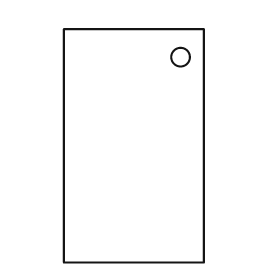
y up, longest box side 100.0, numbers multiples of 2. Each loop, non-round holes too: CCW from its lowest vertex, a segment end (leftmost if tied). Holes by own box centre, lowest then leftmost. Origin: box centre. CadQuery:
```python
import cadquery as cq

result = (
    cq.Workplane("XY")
    .moveTo(-30.0, -50.0)
    .lineTo(30.0, -50.0)
    .lineTo(30.0, 50.0)
    .lineTo(-30.0, 50.0)
    .close()
    .moveTo(20.0, 38.0)
    .circle(4.0)
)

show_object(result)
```